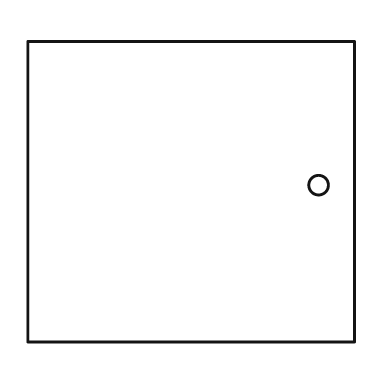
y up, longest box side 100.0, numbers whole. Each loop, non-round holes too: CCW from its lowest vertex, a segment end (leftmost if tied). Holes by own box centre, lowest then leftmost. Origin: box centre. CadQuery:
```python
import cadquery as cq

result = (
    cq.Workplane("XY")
    .moveTo(-50.0, -46.0)
    .lineTo(50.0, -46.0)
    .lineTo(50.0, 46.0)
    .lineTo(-50.0, 46.0)
    .close()
    .moveTo(39.0, 2.0)
    .circle(3.0)
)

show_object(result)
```